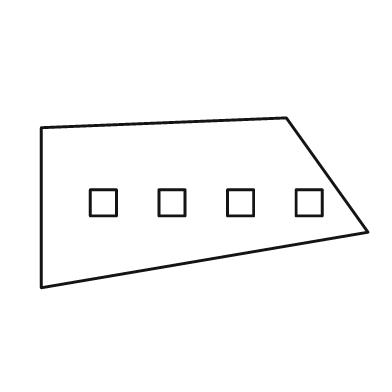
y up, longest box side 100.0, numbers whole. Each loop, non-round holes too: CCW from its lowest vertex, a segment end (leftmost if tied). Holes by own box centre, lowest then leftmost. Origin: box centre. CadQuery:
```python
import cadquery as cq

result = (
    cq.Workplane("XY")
    .moveTo(-50.0, -26.0)
    .lineTo(50.0, -9.0)
    .lineTo(25.0, 26.0)
    .lineTo(-50.0, 23.0)
    .close()
    .moveTo(-35.0, -4.0)
    .lineTo(-27.0, -4.0)
    .lineTo(-27.0, 4.0)
    .lineTo(-35.0, 4.0)
    .close()
    .moveTo(-14.0, -4.0)
    .lineTo(-6.0, -4.0)
    .lineTo(-6.0, 4.0)
    .lineTo(-14.0, 4.0)
    .close()
    .moveTo(7.0, -4.0)
    .lineTo(15.0, -4.0)
    .lineTo(15.0, 4.0)
    .lineTo(7.0, 4.0)
    .close()
    .moveTo(28.0, -4.0)
    .lineTo(36.0, -4.0)
    .lineTo(36.0, 4.0)
    .lineTo(28.0, 4.0)
    .close()
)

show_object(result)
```